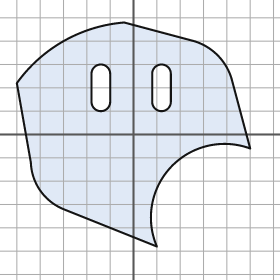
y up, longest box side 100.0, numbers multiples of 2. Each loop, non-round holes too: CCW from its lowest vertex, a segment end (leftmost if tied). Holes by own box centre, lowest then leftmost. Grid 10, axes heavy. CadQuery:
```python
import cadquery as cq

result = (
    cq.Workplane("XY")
    .moveTo(10.0, -48.0)
    .threePointArc((16.0, -14.0), (50.0, -6.0))
    .lineTo(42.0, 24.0)
    .threePointArc((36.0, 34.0), (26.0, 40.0))
    .lineTo(-4.0, 48.0)
    .threePointArc((-30.0, 40.0), (-50.0, 22.0))
    .lineTo(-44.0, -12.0)
    .threePointArc((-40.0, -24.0), (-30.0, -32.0))
    .close()
    .moveTo(-18.0, 14.0)
    .threePointArc((-14.0, 10.0), (-10.0, 14.0))
    .lineTo(-10.0, 26.0)
    .threePointArc((-14.0, 30.0), (-18.0, 26.0))
    .close()
    .moveTo(8.0, 14.0)
    .threePointArc((12.0, 10.0), (16.0, 14.0))
    .lineTo(16.0, 26.0)
    .threePointArc((12.0, 30.0), (8.0, 26.0))
    .close()
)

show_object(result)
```